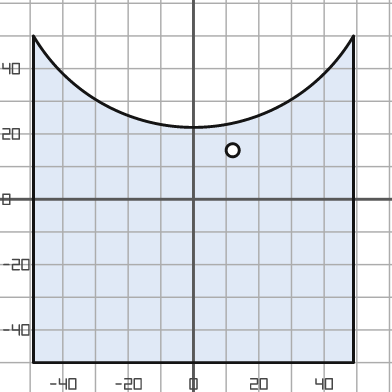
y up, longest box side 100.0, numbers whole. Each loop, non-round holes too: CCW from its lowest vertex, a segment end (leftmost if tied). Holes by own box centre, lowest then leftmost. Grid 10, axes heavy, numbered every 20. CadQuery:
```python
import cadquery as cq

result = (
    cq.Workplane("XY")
    .moveTo(-49.0, -50.0)
    .lineTo(49.0, -50.0)
    .lineTo(49.0, 50.0)
    .threePointArc((0.0, 22.0), (-49.0, 50.0))
    .close()
    .moveTo(12.0, 15.0)
    .circle(2.0)
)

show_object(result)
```